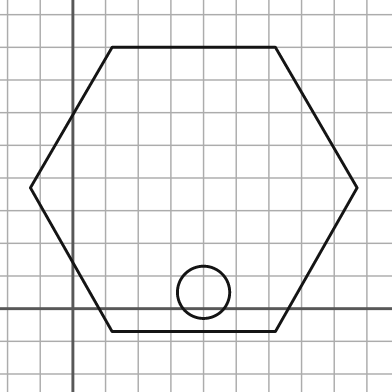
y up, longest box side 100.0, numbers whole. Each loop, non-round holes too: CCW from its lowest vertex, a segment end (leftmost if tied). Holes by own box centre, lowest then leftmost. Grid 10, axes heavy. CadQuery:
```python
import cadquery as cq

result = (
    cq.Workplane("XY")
    .moveTo(12.0, -7.0)
    .lineTo(62.0, -7.0)
    .lineTo(87.0, 37.0)
    .lineTo(62.0, 80.0)
    .lineTo(12.0, 80.0)
    .lineTo(-13.0, 37.0)
    .close()
    .moveTo(40.0, 5.0)
    .circle(8.0)
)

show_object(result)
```